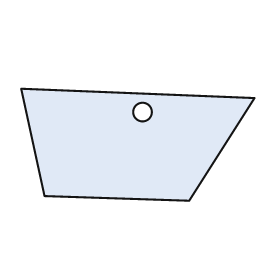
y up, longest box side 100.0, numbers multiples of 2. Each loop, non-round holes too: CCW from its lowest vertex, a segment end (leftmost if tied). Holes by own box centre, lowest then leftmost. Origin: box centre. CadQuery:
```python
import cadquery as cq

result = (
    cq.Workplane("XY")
    .moveTo(22.0, -24.0)
    .lineTo(50.0, 20.0)
    .lineTo(-50.0, 24.0)
    .lineTo(-40.0, -22.0)
    .close()
    .moveTo(2.0, 14.0)
    .circle(4.0)
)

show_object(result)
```